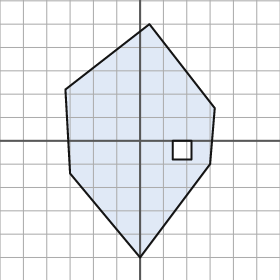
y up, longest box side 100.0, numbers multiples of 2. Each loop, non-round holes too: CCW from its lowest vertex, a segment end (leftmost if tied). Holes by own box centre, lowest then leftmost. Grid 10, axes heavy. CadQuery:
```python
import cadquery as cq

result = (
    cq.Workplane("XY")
    .moveTo(0.0, -50.0)
    .lineTo(30.0, -10.0)
    .lineTo(32.0, 14.0)
    .lineTo(4.0, 50.0)
    .lineTo(-32.0, 22.0)
    .lineTo(-30.0, -14.0)
    .close()
    .moveTo(14.0, -8.0)
    .lineTo(22.0, -8.0)
    .lineTo(22.0, 0.0)
    .lineTo(14.0, 0.0)
    .close()
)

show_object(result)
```